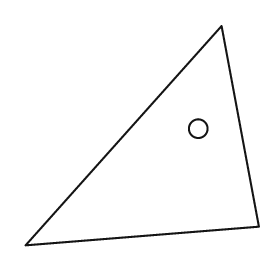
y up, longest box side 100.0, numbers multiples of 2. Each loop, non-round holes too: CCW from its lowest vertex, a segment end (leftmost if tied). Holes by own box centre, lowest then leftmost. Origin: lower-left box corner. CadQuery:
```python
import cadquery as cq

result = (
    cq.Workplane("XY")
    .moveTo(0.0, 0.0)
    .lineTo(100.0, 8.0)
    .lineTo(84.0, 94.0)
    .close()
    .moveTo(74.0, 50.0)
    .circle(4.0)
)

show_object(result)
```